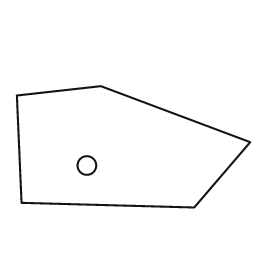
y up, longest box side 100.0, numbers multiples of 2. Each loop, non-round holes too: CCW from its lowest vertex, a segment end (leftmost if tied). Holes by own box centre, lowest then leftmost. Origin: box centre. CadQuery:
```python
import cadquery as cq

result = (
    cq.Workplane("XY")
    .moveTo(26.0, -26.0)
    .lineTo(50.0, 2.0)
    .lineTo(-14.0, 26.0)
    .lineTo(-50.0, 22.0)
    .lineTo(-48.0, -24.0)
    .close()
    .moveTo(-20.0, -8.0)
    .circle(4.0)
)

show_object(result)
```